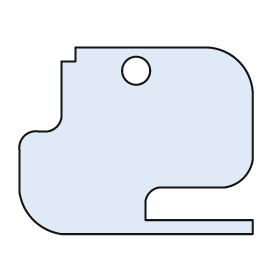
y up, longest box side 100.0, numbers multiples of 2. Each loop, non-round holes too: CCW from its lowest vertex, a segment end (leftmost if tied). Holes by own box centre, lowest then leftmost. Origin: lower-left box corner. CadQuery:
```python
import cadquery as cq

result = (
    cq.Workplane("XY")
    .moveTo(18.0, 0.0)
    .lineTo(100.0, 0.0)
    .lineTo(100.0, 6.0)
    .lineTo(54.0, 6.0)
    .lineTo(54.0, 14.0)
    .threePointArc((56.0, 18.0), (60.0, 20.0))
    .lineTo(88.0, 20.0)
    .threePointArc((96.0, 24.0), (100.0, 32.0))
    .lineTo(100.0, 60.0)
    .threePointArc((94.0, 74.0), (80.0, 80.0))
    .lineTo(24.0, 80.0)
    .lineTo(24.0, 74.0)
    .lineTo(18.0, 74.0)
    .lineTo(18.0, 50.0)
    .threePointArc((16.0, 46.0), (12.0, 44.0))
    .lineTo(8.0, 44.0)
    .threePointArc((2.0, 42.0), (0.0, 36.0))
    .lineTo(0.0, 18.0)
    .threePointArc((6.0, 6.0), (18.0, 0.0))
    .close()
    .moveTo(50.0, 70.0)
    .circle(6.0)
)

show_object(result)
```